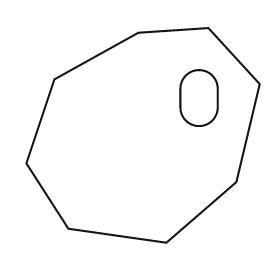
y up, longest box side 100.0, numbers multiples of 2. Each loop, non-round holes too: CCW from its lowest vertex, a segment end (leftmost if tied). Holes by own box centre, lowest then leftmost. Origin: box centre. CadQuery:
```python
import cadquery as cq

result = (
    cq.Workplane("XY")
    .moveTo(10.0, -46.0)
    .lineTo(40.0, -20.0)
    .lineTo(50.0, 22.0)
    .lineTo(28.0, 46.0)
    .lineTo(-2.0, 44.0)
    .lineTo(-38.0, 24.0)
    .lineTo(-50.0, -12.0)
    .lineTo(-32.0, -40.0)
    .close()
    .moveTo(16.0, 12.0)
    .threePointArc((24.0, 4.0), (32.0, 12.0))
    .lineTo(32.0, 20.0)
    .threePointArc((24.0, 28.0), (16.0, 20.0))
    .close()
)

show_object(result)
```